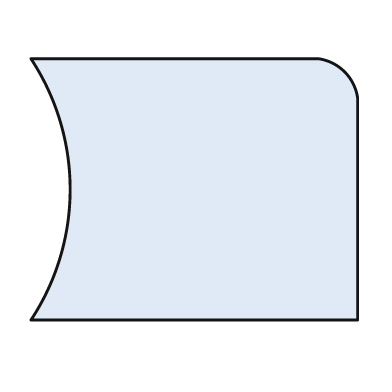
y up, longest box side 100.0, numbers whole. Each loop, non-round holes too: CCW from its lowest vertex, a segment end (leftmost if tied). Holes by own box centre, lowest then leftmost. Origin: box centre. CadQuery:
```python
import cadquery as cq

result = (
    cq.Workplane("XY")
    .moveTo(-50.0, -40.0)
    .lineTo(50.0, -40.0)
    .lineTo(50.0, 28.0)
    .threePointArc((46.0, 36.0), (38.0, 40.0))
    .lineTo(-50.0, 40.0)
    .threePointArc((-38.0, 0.0), (-50.0, -40.0))
    .close()
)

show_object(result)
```